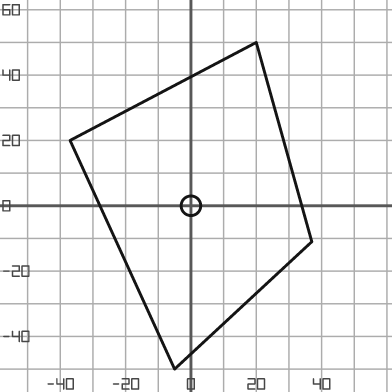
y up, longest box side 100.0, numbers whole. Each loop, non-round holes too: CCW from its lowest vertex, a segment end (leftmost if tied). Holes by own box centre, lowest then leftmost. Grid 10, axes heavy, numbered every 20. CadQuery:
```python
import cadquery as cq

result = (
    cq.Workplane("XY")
    .moveTo(-5.0, -50.0)
    .lineTo(37.0, -11.0)
    .lineTo(20.0, 50.0)
    .lineTo(-37.0, 20.0)
    .close()
    .moveTo(0.0, 0.0)
    .circle(3.0)
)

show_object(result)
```